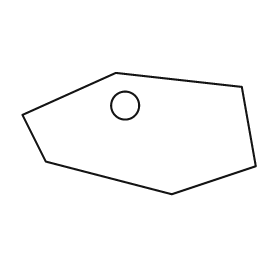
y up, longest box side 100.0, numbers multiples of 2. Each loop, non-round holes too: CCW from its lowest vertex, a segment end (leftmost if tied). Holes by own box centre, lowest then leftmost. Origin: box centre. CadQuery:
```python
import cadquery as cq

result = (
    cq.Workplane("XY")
    .moveTo(14.0, -26.0)
    .lineTo(50.0, -14.0)
    .lineTo(44.0, 20.0)
    .lineTo(-10.0, 26.0)
    .lineTo(-50.0, 8.0)
    .lineTo(-40.0, -12.0)
    .close()
    .moveTo(-6.0, 12.0)
    .circle(6.0)
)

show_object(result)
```